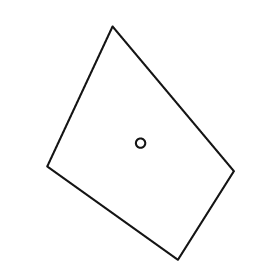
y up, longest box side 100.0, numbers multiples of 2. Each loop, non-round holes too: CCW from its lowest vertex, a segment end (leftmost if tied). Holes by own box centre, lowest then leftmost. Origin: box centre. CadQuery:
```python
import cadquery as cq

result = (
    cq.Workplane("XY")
    .moveTo(16.0, -50.0)
    .lineTo(40.0, -12.0)
    .lineTo(-12.0, 50.0)
    .lineTo(-40.0, -10.0)
    .close()
    .moveTo(0.0, 0.0)
    .circle(2.0)
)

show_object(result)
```